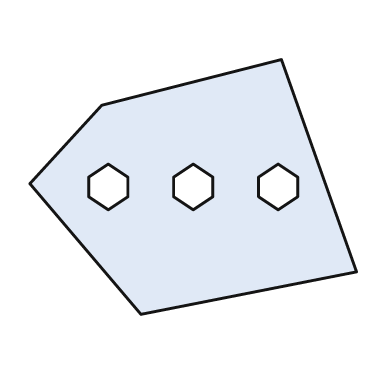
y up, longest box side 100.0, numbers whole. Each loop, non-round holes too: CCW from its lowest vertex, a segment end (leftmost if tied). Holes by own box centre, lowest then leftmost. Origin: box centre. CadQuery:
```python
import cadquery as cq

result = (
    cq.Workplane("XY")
    .moveTo(-16.0, -39.0)
    .lineTo(50.0, -26.0)
    .lineTo(27.0, 39.0)
    .lineTo(-28.0, 25.0)
    .lineTo(-50.0, 1.0)
    .close()
    .moveTo(-26.0, -7.0)
    .lineTo(-20.0, -3.0)
    .lineTo(-20.0, 3.0)
    .lineTo(-26.0, 7.0)
    .lineTo(-32.0, 3.0)
    .lineTo(-32.0, -3.0)
    .close()
    .moveTo(0.0, -7.0)
    .lineTo(6.0, -3.0)
    .lineTo(6.0, 3.0)
    .lineTo(0.0, 7.0)
    .lineTo(-6.0, 3.0)
    .lineTo(-6.0, -3.0)
    .close()
    .moveTo(26.0, -7.0)
    .lineTo(32.0, -3.0)
    .lineTo(32.0, 3.0)
    .lineTo(26.0, 7.0)
    .lineTo(20.0, 3.0)
    .lineTo(20.0, -3.0)
    .close()
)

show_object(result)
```